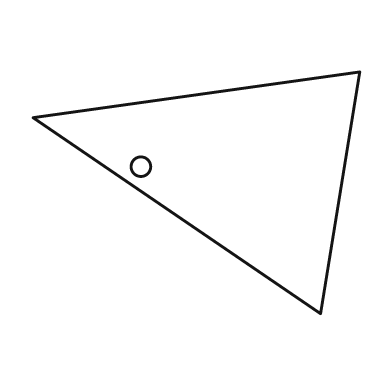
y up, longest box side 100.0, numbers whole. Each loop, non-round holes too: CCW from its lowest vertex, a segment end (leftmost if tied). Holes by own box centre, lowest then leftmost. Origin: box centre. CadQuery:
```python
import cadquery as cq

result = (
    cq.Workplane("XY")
    .moveTo(38.0, -37.0)
    .lineTo(50.0, 37.0)
    .lineTo(-50.0, 23.0)
    .close()
    .moveTo(-17.0, 8.0)
    .circle(3.0)
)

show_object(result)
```